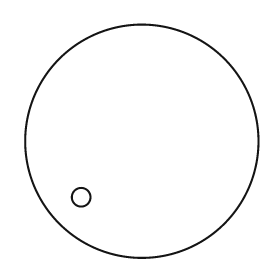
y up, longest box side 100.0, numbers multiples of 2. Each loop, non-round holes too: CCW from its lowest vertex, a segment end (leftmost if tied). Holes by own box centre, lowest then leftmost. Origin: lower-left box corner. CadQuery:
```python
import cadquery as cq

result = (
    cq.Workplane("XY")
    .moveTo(50.0, 50.0)
    .circle(50.0)
    .moveTo(24.0, 26.0)
    .circle(4.0)
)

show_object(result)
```